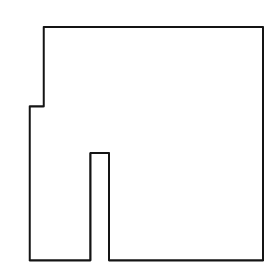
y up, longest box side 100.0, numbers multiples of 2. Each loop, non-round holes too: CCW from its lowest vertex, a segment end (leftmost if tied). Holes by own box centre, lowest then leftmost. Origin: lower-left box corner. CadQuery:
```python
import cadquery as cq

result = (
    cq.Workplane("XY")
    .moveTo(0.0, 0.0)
    .lineTo(26.0, 0.0)
    .lineTo(26.0, 46.0)
    .lineTo(34.0, 46.0)
    .lineTo(34.0, 0.0)
    .lineTo(100.0, 0.0)
    .lineTo(100.0, 100.0)
    .lineTo(6.0, 100.0)
    .lineTo(6.0, 66.0)
    .lineTo(0.0, 66.0)
    .close()
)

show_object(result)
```